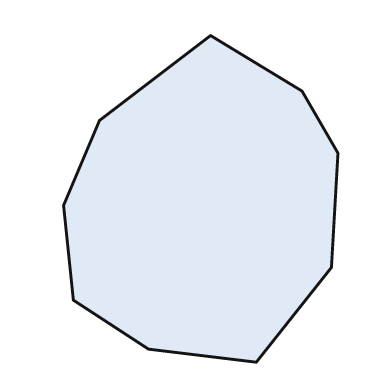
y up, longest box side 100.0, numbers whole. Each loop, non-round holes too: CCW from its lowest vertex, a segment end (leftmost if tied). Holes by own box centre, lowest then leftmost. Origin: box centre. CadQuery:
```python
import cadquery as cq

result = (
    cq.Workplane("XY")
    .moveTo(17.0, -50.0)
    .lineTo(40.0, -21.0)
    .lineTo(42.0, 14.0)
    .lineTo(31.0, 33.0)
    .lineTo(3.0, 50.0)
    .lineTo(-31.0, 24.0)
    .lineTo(-42.0, -2.0)
    .lineTo(-39.0, -31.0)
    .lineTo(-16.0, -46.0)
    .close()
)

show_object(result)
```